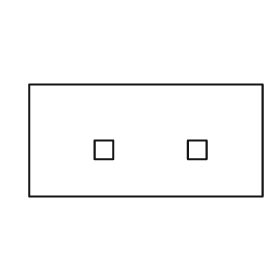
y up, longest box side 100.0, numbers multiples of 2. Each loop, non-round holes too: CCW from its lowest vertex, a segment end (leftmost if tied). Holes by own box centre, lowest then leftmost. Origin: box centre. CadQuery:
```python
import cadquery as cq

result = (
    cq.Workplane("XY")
    .moveTo(-50.0, -24.0)
    .lineTo(50.0, -24.0)
    .lineTo(50.0, 24.0)
    .lineTo(-50.0, 24.0)
    .close()
    .moveTo(-22.0, -8.0)
    .lineTo(-14.0, -8.0)
    .lineTo(-14.0, 0.0)
    .lineTo(-22.0, 0.0)
    .close()
    .moveTo(18.0, -8.0)
    .lineTo(26.0, -8.0)
    .lineTo(26.0, 0.0)
    .lineTo(18.0, 0.0)
    .close()
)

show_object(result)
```